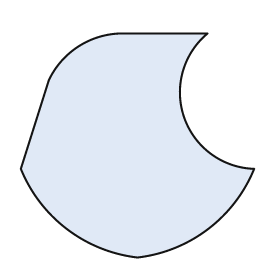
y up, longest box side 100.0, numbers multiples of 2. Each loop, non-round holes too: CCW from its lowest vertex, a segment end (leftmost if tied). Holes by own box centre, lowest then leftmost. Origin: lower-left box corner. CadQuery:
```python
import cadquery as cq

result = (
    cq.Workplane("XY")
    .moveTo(50.0, 0.0)
    .threePointArc((80.0, 12.0), (100.0, 38.0))
    .threePointArc((70.0, 60.0), (80.0, 96.0))
    .lineTo(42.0, 96.0)
    .threePointArc((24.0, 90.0), (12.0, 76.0))
    .lineTo(0.0, 38.0)
    .threePointArc((20.0, 12.0), (50.0, 0.0))
    .close()
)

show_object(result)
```